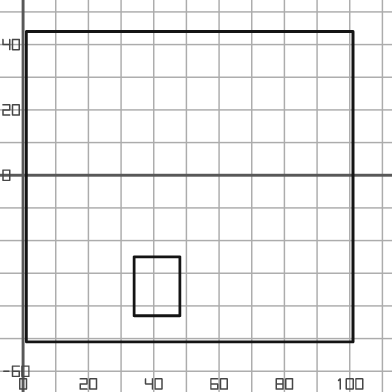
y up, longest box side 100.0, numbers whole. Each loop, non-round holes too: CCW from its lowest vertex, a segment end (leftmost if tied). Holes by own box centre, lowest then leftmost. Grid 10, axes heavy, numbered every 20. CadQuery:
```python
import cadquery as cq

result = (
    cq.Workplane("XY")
    .moveTo(1.0, -51.0)
    .lineTo(101.0, -51.0)
    .lineTo(101.0, 44.0)
    .lineTo(1.0, 44.0)
    .close()
    .moveTo(34.0, -43.0)
    .lineTo(48.0, -43.0)
    .lineTo(48.0, -25.0)
    .lineTo(34.0, -25.0)
    .close()
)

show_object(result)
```